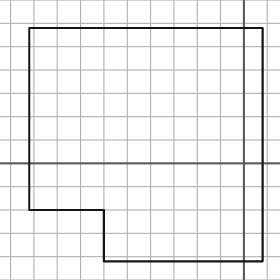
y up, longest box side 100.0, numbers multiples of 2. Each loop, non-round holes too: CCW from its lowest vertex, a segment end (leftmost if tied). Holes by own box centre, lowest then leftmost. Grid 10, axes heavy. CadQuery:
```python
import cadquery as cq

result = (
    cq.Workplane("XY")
    .moveTo(-60.0, -42.0)
    .lineTo(8.0, -42.0)
    .lineTo(8.0, 58.0)
    .lineTo(-92.0, 58.0)
    .lineTo(-92.0, -20.0)
    .lineTo(-60.0, -20.0)
    .close()
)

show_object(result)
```